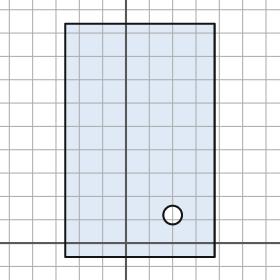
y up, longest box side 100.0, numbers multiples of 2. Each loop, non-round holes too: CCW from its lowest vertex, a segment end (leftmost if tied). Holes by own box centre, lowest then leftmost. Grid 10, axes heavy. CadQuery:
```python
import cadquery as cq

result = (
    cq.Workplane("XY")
    .moveTo(-26.0, -6.0)
    .lineTo(38.0, -6.0)
    .lineTo(38.0, 94.0)
    .lineTo(-26.0, 94.0)
    .close()
    .moveTo(20.0, 12.0)
    .circle(4.0)
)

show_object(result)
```